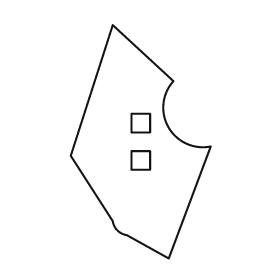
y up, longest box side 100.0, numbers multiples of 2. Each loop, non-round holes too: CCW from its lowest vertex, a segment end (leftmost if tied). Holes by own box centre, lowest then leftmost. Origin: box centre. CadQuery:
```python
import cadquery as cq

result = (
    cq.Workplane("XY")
    .moveTo(12.0, -50.0)
    .lineTo(30.0, -2.0)
    .threePointArc((12.0, 6.0), (14.0, 26.0))
    .lineTo(-12.0, 50.0)
    .lineTo(-30.0, -6.0)
    .lineTo(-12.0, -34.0)
    .threePointArc((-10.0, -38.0), (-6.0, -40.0))
    .close()
    .moveTo(-4.0, -12.0)
    .lineTo(4.0, -12.0)
    .lineTo(4.0, -4.0)
    .lineTo(-4.0, -4.0)
    .close()
    .moveTo(-4.0, 4.0)
    .lineTo(4.0, 4.0)
    .lineTo(4.0, 12.0)
    .lineTo(-4.0, 12.0)
    .close()
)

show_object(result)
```